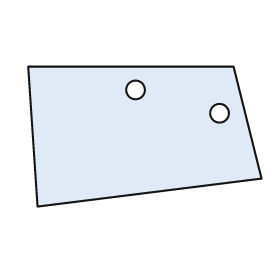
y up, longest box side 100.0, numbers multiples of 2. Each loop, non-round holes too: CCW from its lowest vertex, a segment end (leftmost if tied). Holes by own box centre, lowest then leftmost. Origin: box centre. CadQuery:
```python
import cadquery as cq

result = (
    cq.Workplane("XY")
    .moveTo(-46.0, -30.0)
    .lineTo(50.0, -18.0)
    .lineTo(38.0, 30.0)
    .lineTo(-50.0, 30.0)
    .close()
    .moveTo(32.0, 10.0)
    .circle(4.0)
    .moveTo(-4.0, 20.0)
    .circle(4.0)
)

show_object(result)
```